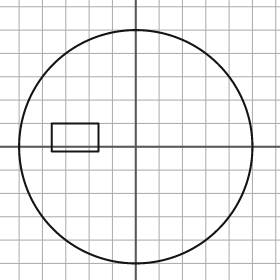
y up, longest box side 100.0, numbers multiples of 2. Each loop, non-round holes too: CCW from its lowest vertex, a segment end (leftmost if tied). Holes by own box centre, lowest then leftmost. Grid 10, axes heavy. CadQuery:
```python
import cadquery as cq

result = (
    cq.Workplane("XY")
    .moveTo(0.0, 0.0)
    .circle(50.0)
    .moveTo(-36.0, -2.0)
    .lineTo(-16.0, -2.0)
    .lineTo(-16.0, 10.0)
    .lineTo(-36.0, 10.0)
    .close()
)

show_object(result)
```